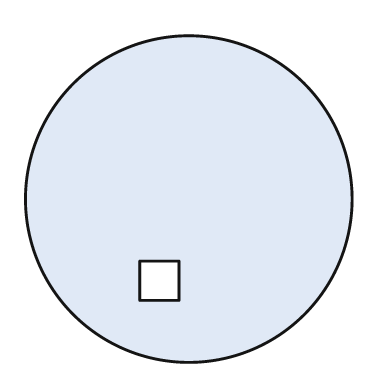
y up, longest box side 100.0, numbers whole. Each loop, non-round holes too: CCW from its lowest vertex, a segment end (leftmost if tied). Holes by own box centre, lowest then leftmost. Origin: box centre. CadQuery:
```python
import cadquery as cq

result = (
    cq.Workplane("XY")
    .moveTo(0.0, 0.0)
    .circle(50.0)
    .moveTo(-15.0, -31.0)
    .lineTo(-3.0, -31.0)
    .lineTo(-3.0, -19.0)
    .lineTo(-15.0, -19.0)
    .close()
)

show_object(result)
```